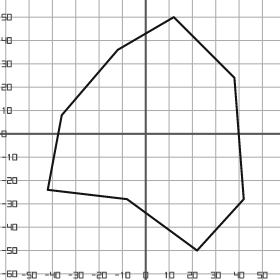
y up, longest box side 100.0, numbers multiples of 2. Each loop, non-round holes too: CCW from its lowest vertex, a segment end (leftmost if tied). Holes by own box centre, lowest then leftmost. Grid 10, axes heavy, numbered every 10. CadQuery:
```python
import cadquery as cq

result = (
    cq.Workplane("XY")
    .moveTo(22.0, -50.0)
    .lineTo(42.0, -28.0)
    .lineTo(38.0, 24.0)
    .lineTo(12.0, 50.0)
    .lineTo(-12.0, 36.0)
    .lineTo(-36.0, 8.0)
    .lineTo(-42.0, -24.0)
    .lineTo(-8.0, -28.0)
    .close()
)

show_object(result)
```